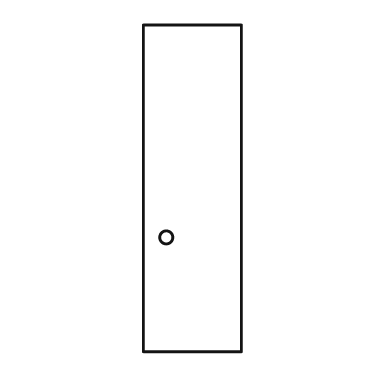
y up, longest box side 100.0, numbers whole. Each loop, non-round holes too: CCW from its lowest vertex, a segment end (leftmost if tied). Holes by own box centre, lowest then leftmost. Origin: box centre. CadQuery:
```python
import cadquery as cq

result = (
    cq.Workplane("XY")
    .moveTo(-15.0, -50.0)
    .lineTo(15.0, -50.0)
    .lineTo(15.0, 50.0)
    .lineTo(-15.0, 50.0)
    .close()
    .moveTo(-8.0, -15.0)
    .circle(2.0)
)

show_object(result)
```